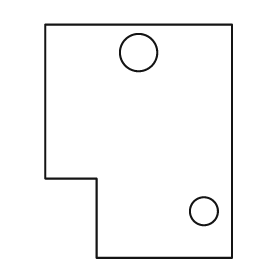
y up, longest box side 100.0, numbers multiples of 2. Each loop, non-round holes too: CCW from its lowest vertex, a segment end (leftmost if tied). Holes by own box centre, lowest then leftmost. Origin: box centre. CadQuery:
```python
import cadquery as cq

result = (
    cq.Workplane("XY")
    .moveTo(-18.0, -50.0)
    .lineTo(40.0, -50.0)
    .lineTo(40.0, 50.0)
    .lineTo(-40.0, 50.0)
    .lineTo(-40.0, -16.0)
    .lineTo(-18.0, -16.0)
    .close()
    .moveTo(28.0, -30.0)
    .circle(6.0)
    .moveTo(0.0, 38.0)
    .circle(8.0)
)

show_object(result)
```